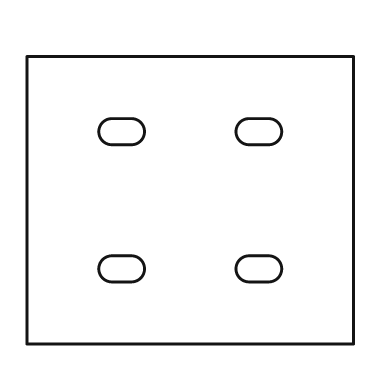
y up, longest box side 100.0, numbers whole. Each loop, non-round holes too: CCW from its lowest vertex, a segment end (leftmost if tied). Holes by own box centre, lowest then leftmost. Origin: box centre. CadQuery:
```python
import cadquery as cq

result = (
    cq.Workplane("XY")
    .moveTo(-50.0, -44.0)
    .lineTo(50.0, -44.0)
    .lineTo(50.0, 44.0)
    .lineTo(-50.0, 44.0)
    .close()
    .moveTo(-24.0, -25.0)
    .lineTo(-18.0, -25.0)
    .threePointArc((-14.0, -21.0), (-18.0, -17.0))
    .lineTo(-24.0, -17.0)
    .threePointArc((-28.0, -21.0), (-24.0, -25.0))
    .close()
    .moveTo(18.0, -25.0)
    .lineTo(24.0, -25.0)
    .threePointArc((28.0, -21.0), (24.0, -17.0))
    .lineTo(18.0, -17.0)
    .threePointArc((14.0, -21.0), (18.0, -25.0))
    .close()
    .moveTo(-24.0, 17.0)
    .lineTo(-18.0, 17.0)
    .threePointArc((-14.0, 21.0), (-18.0, 25.0))
    .lineTo(-24.0, 25.0)
    .threePointArc((-28.0, 21.0), (-24.0, 17.0))
    .close()
    .moveTo(18.0, 17.0)
    .lineTo(24.0, 17.0)
    .threePointArc((28.0, 21.0), (24.0, 25.0))
    .lineTo(18.0, 25.0)
    .threePointArc((14.0, 21.0), (18.0, 17.0))
    .close()
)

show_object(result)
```